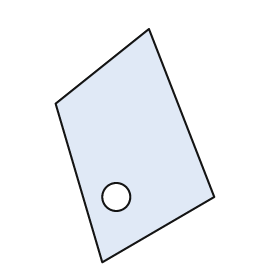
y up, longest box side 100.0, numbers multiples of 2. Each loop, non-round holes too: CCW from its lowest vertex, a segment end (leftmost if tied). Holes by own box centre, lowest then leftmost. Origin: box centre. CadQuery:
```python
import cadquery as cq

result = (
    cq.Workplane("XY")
    .moveTo(-14.0, -50.0)
    .lineTo(34.0, -22.0)
    .lineTo(6.0, 50.0)
    .lineTo(-34.0, 18.0)
    .close()
    .moveTo(-8.0, -22.0)
    .circle(6.0)
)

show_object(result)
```